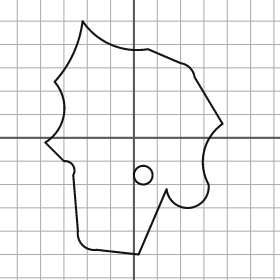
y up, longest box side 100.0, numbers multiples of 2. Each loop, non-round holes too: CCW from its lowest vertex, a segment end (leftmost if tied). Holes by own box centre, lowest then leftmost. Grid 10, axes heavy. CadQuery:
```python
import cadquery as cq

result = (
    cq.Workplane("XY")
    .moveTo(2.0, -50.0)
    .lineTo(14.0, -22.0)
    .threePointArc((24.0, -30.0), (32.0, -20.0))
    .threePointArc((30.0, -6.0), (38.0, 6.0))
    .lineTo(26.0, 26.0)
    .threePointArc((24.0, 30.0), (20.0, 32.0))
    .lineTo(6.0, 38.0)
    .threePointArc((-10.0, 40.0), (-22.0, 50.0))
    .threePointArc((-26.0, 36.0), (-34.0, 24.0))
    .threePointArc((-30.0, 10.0), (-38.0, -2.0))
    .lineTo(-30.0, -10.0)
    .threePointArc((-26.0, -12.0), (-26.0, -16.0))
    .lineTo(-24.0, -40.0)
    .threePointArc((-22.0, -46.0), (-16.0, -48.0))
    .close()
    .moveTo(4.0, -16.0)
    .circle(4.0)
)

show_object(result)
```